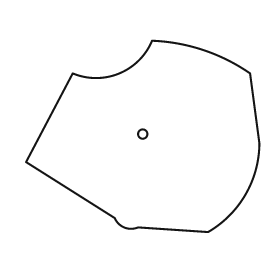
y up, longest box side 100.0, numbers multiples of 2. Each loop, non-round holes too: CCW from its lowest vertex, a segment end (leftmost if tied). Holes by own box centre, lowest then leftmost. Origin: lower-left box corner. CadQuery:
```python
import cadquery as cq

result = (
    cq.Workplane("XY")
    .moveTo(78.0, 0.0)
    .threePointArc((94.0, 16.0), (100.0, 38.0))
    .lineTo(96.0, 68.0)
    .threePointArc((76.0, 78.0), (54.0, 82.0))
    .threePointArc((40.0, 68.0), (20.0, 68.0))
    .lineTo(0.0, 30.0)
    .lineTo(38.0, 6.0)
    .threePointArc((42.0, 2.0), (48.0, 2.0))
    .close()
    .moveTo(50.0, 42.0)
    .circle(2.0)
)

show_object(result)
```